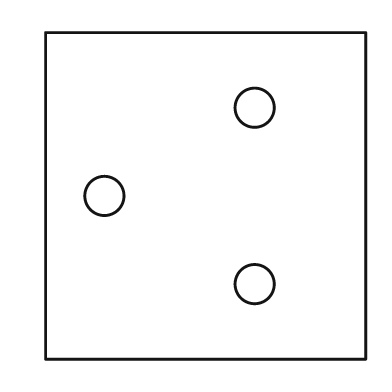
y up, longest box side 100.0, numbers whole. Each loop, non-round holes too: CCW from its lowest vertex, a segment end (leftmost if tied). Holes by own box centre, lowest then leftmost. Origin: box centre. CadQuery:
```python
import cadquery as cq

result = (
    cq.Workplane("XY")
    .moveTo(-49.0, -50.0)
    .lineTo(49.0, -50.0)
    .lineTo(49.0, 50.0)
    .lineTo(-49.0, 50.0)
    .close()
    .moveTo(15.0, -27.0)
    .circle(6.0)
    .moveTo(-31.0, 0.0)
    .circle(6.0)
    .moveTo(15.0, 27.0)
    .circle(6.0)
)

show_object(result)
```